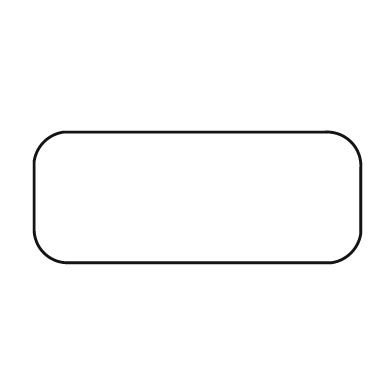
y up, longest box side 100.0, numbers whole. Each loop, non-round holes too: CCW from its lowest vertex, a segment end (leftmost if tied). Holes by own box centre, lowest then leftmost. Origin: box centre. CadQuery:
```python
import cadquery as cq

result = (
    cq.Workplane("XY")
    .moveTo(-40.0, -20.0)
    .lineTo(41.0, -20.0)
    .threePointArc((47.0, -17.0), (50.0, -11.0))
    .lineTo(50.0, 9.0)
    .threePointArc((47.0, 17.0), (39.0, 20.0))
    .lineTo(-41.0, 20.0)
    .threePointArc((-47.0, 17.0), (-50.0, 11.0))
    .lineTo(-50.0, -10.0)
    .threePointArc((-47.0, -17.0), (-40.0, -20.0))
    .close()
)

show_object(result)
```